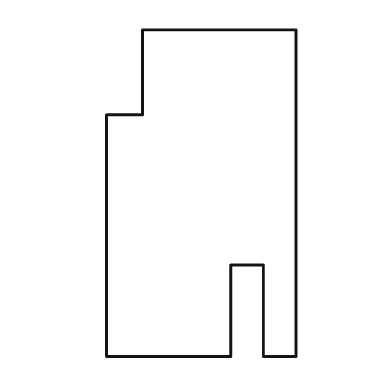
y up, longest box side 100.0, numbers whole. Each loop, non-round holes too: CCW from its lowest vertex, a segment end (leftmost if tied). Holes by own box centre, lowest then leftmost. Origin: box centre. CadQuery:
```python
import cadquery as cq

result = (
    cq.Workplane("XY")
    .moveTo(-29.0, -50.0)
    .lineTo(9.0, -50.0)
    .lineTo(9.0, -22.0)
    .lineTo(19.0, -22.0)
    .lineTo(19.0, -50.0)
    .lineTo(29.0, -50.0)
    .lineTo(29.0, 50.0)
    .lineTo(-18.0, 50.0)
    .lineTo(-18.0, 24.0)
    .lineTo(-29.0, 24.0)
    .close()
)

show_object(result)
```